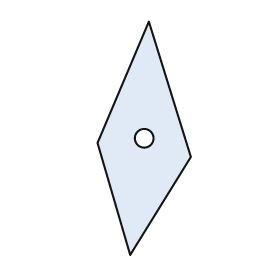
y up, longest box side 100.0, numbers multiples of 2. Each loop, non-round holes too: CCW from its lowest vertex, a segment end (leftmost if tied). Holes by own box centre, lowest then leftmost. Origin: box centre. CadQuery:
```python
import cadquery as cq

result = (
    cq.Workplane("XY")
    .moveTo(-6.0, -50.0)
    .lineTo(20.0, -8.0)
    .lineTo(2.0, 50.0)
    .lineTo(-20.0, -2.0)
    .close()
    .moveTo(0.0, 0.0)
    .circle(4.0)
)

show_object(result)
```